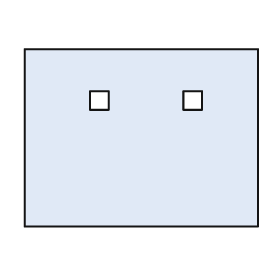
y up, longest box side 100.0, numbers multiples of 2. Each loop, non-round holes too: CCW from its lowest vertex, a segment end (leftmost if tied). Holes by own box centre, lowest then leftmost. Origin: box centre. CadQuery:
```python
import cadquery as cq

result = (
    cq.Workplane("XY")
    .moveTo(-50.0, -38.0)
    .lineTo(50.0, -38.0)
    .lineTo(50.0, 38.0)
    .lineTo(-50.0, 38.0)
    .close()
    .moveTo(-22.0, 12.0)
    .lineTo(-14.0, 12.0)
    .lineTo(-14.0, 20.0)
    .lineTo(-22.0, 20.0)
    .close()
    .moveTo(18.0, 12.0)
    .lineTo(26.0, 12.0)
    .lineTo(26.0, 20.0)
    .lineTo(18.0, 20.0)
    .close()
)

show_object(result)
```